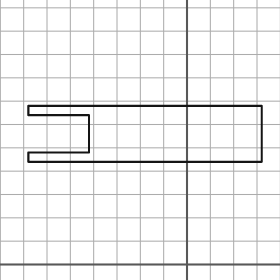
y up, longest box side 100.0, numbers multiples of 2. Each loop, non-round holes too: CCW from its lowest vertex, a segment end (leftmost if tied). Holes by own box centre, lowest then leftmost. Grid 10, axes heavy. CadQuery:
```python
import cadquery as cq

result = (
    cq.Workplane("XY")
    .moveTo(-68.0, 44.0)
    .lineTo(32.0, 44.0)
    .lineTo(32.0, 68.0)
    .lineTo(-68.0, 68.0)
    .lineTo(-68.0, 64.0)
    .lineTo(-42.0, 64.0)
    .lineTo(-42.0, 48.0)
    .lineTo(-68.0, 48.0)
    .close()
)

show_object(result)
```